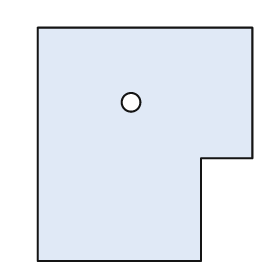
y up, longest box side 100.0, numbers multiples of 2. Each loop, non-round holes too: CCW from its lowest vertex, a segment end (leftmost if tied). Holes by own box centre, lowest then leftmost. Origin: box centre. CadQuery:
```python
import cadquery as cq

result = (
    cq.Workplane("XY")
    .moveTo(-46.0, -50.0)
    .lineTo(24.0, -50.0)
    .lineTo(24.0, -6.0)
    .lineTo(46.0, -6.0)
    .lineTo(46.0, 50.0)
    .lineTo(-46.0, 50.0)
    .close()
    .moveTo(-6.0, 18.0)
    .circle(4.0)
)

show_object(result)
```